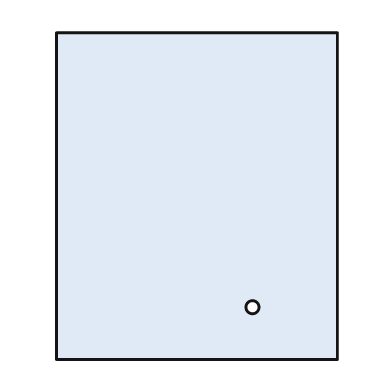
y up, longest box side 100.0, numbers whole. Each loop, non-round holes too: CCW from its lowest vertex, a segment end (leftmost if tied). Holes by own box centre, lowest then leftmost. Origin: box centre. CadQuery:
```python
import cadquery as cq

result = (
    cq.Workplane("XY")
    .moveTo(-43.0, -50.0)
    .lineTo(43.0, -50.0)
    .lineTo(43.0, 50.0)
    .lineTo(-43.0, 50.0)
    .close()
    .moveTo(17.0, -34.0)
    .circle(2.0)
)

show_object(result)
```